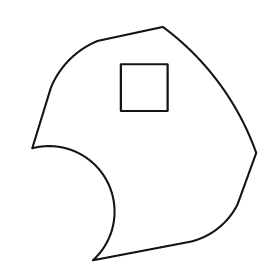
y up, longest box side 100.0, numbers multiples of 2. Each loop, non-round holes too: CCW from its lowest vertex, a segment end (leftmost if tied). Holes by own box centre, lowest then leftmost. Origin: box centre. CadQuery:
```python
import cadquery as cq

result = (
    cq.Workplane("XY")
    .moveTo(-22.0, -50.0)
    .lineTo(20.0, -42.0)
    .threePointArc((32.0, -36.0), (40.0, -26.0))
    .lineTo(48.0, -4.0)
    .threePointArc((32.0, 26.0), (8.0, 50.0))
    .lineTo(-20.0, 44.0)
    .threePointArc((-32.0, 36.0), (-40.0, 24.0))
    .lineTo(-48.0, -2.0)
    .threePointArc((-16.0, -16.0), (-22.0, -50.0))
    .close()
    .moveTo(-10.0, 14.0)
    .lineTo(10.0, 14.0)
    .lineTo(10.0, 34.0)
    .lineTo(-10.0, 34.0)
    .close()
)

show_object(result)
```